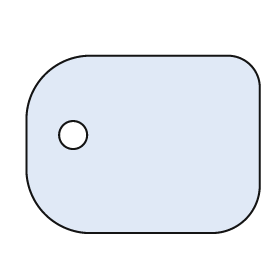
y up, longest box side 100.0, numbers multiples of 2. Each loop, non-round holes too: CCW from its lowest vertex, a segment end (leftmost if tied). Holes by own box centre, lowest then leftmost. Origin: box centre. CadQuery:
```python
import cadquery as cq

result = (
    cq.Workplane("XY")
    .moveTo(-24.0, -38.0)
    .lineTo(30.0, -38.0)
    .threePointArc((44.0, -32.0), (50.0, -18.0))
    .lineTo(50.0, 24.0)
    .threePointArc((46.0, 34.0), (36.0, 38.0))
    .lineTo(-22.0, 38.0)
    .threePointArc((-42.0, 30.0), (-50.0, 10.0))
    .lineTo(-50.0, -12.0)
    .threePointArc((-42.0, -30.0), (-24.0, -38.0))
    .close()
    .moveTo(-30.0, 4.0)
    .circle(6.0)
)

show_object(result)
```